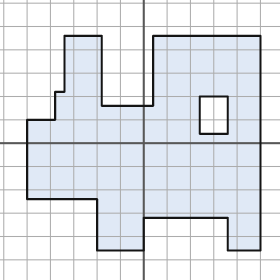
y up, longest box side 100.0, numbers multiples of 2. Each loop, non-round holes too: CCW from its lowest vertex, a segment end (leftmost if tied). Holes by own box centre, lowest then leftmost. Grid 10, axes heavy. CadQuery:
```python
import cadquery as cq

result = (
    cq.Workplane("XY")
    .moveTo(-20.0, -46.0)
    .lineTo(0.0, -46.0)
    .lineTo(0.0, -32.0)
    .lineTo(36.0, -32.0)
    .lineTo(36.0, -46.0)
    .lineTo(50.0, -46.0)
    .lineTo(50.0, 46.0)
    .lineTo(4.0, 46.0)
    .lineTo(4.0, 16.0)
    .lineTo(-18.0, 16.0)
    .lineTo(-18.0, 46.0)
    .lineTo(-34.0, 46.0)
    .lineTo(-34.0, 22.0)
    .lineTo(-38.0, 22.0)
    .lineTo(-38.0, 10.0)
    .lineTo(-50.0, 10.0)
    .lineTo(-50.0, -24.0)
    .lineTo(-20.0, -24.0)
    .close()
    .moveTo(24.0, 4.0)
    .lineTo(36.0, 4.0)
    .lineTo(36.0, 20.0)
    .lineTo(24.0, 20.0)
    .close()
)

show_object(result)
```